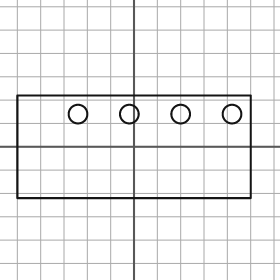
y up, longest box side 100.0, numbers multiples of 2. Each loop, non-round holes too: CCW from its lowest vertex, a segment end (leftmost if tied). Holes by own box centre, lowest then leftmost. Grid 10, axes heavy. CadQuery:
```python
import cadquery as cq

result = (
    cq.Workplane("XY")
    .moveTo(-50.0, -22.0)
    .lineTo(50.0, -22.0)
    .lineTo(50.0, 22.0)
    .lineTo(-50.0, 22.0)
    .close()
    .moveTo(-24.0, 14.0)
    .circle(4.0)
    .moveTo(-2.0, 14.0)
    .circle(4.0)
    .moveTo(20.0, 14.0)
    .circle(4.0)
    .moveTo(42.0, 14.0)
    .circle(4.0)
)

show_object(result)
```